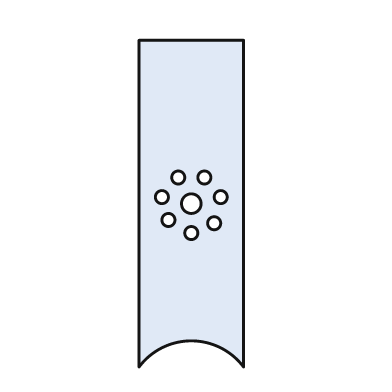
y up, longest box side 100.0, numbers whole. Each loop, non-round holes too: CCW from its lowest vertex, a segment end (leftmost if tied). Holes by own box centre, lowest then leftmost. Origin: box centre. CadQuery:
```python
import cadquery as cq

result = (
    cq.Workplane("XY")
    .moveTo(-16.0, -50.0)
    .threePointArc((0.0, -42.0), (16.0, -50.0))
    .lineTo(16.0, 50.0)
    .lineTo(-16.0, 50.0)
    .close()
    .moveTo(0.0, -9.0)
    .circle(2.0)
    .moveTo(7.0, -6.0)
    .circle(2.0)
    .moveTo(-7.0, -5.0)
    .circle(2.0)
    .moveTo(0.0, 0.0)
    .circle(3.0)
    .moveTo(-9.0, 2.0)
    .circle(2.0)
    .moveTo(9.0, 2.0)
    .circle(2.0)
    .moveTo(-4.0, 8.0)
    .circle(2.0)
    .moveTo(4.0, 8.0)
    .circle(2.0)
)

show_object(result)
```